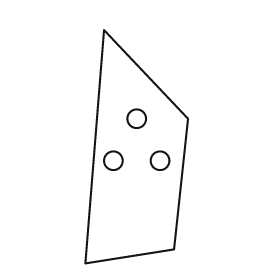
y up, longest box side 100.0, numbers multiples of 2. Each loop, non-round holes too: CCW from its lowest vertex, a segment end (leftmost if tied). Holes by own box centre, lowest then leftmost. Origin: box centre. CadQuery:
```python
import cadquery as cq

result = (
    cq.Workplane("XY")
    .moveTo(-22.0, -50.0)
    .lineTo(16.0, -44.0)
    .lineTo(22.0, 12.0)
    .lineTo(-14.0, 50.0)
    .close()
    .moveTo(-10.0, -6.0)
    .circle(4.0)
    .moveTo(10.0, -6.0)
    .circle(4.0)
    .moveTo(0.0, 12.0)
    .circle(4.0)
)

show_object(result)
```